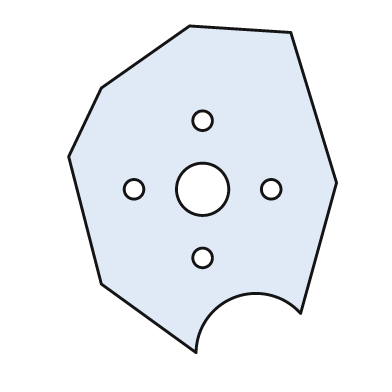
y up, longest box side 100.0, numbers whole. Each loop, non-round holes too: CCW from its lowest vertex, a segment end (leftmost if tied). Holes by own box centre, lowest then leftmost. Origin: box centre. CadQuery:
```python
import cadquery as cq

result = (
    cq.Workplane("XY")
    .moveTo(-2.0, -50.0)
    .threePointArc((10.0, -33.0), (30.0, -38.0))
    .lineTo(41.0, 2.0)
    .lineTo(27.0, 48.0)
    .lineTo(-4.0, 50.0)
    .lineTo(-31.0, 31.0)
    .lineTo(-41.0, 10.0)
    .lineTo(-31.0, -29.0)
    .close()
    .moveTo(0.0, -21.0)
    .circle(3.0)
    .moveTo(-21.0, 0.0)
    .circle(3.0)
    .moveTo(0.0, 0.0)
    .circle(8.0)
    .moveTo(21.0, 0.0)
    .circle(3.0)
    .moveTo(0.0, 21.0)
    .circle(3.0)
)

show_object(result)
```